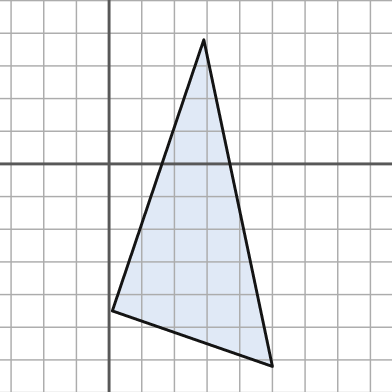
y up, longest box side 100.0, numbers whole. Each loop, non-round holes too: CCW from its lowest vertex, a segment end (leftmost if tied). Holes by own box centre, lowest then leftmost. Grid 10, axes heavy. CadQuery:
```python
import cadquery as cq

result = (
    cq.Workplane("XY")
    .moveTo(50.0, -62.0)
    .lineTo(29.0, 38.0)
    .lineTo(1.0, -45.0)
    .close()
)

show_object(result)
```